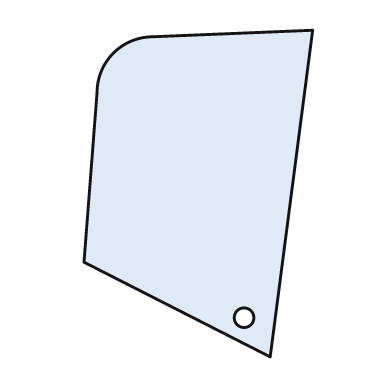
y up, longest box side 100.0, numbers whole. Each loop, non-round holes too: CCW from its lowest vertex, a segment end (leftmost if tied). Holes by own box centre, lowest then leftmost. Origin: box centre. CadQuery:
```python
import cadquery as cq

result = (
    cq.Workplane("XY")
    .moveTo(22.0, -50.0)
    .lineTo(35.0, 50.0)
    .lineTo(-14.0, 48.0)
    .threePointArc((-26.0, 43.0), (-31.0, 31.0))
    .lineTo(-35.0, -21.0)
    .close()
    .moveTo(14.0, -38.0)
    .circle(3.0)
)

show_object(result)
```